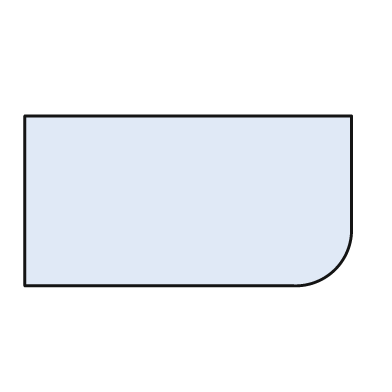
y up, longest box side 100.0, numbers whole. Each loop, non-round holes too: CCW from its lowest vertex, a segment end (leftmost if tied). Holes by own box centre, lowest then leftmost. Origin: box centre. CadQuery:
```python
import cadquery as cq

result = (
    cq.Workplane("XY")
    .moveTo(-50.0, -26.0)
    .lineTo(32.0, -26.0)
    .threePointArc((45.0, -21.0), (50.0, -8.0))
    .lineTo(50.0, 26.0)
    .lineTo(-50.0, 26.0)
    .close()
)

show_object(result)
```